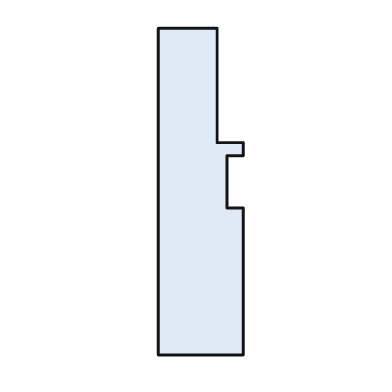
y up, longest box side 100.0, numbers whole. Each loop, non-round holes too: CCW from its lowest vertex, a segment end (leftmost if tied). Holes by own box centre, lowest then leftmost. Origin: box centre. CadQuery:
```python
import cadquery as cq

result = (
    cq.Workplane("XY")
    .moveTo(-13.0, -50.0)
    .lineTo(13.0, -50.0)
    .lineTo(13.0, -5.0)
    .lineTo(8.0, -5.0)
    .lineTo(8.0, 11.0)
    .lineTo(13.0, 11.0)
    .lineTo(13.0, 15.0)
    .lineTo(5.0, 15.0)
    .lineTo(5.0, 50.0)
    .lineTo(-13.0, 50.0)
    .close()
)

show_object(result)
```